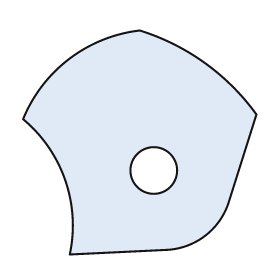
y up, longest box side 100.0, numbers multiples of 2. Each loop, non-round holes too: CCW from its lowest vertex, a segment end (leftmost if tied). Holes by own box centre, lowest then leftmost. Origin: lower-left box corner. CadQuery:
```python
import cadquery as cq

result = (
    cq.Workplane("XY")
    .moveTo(20.0, 0.0)
    .lineTo(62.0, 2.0)
    .threePointArc((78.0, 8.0), (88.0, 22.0))
    .lineTo(100.0, 60.0)
    .threePointArc((78.0, 82.0), (50.0, 96.0))
    .threePointArc((20.0, 84.0), (0.0, 58.0))
    .threePointArc((18.0, 32.0), (20.0, 0.0))
    .close()
    .moveTo(56.0, 36.0)
    .circle(10.0)
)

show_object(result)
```